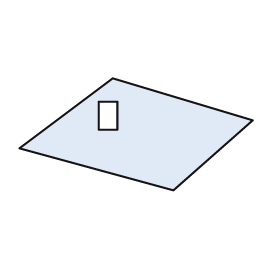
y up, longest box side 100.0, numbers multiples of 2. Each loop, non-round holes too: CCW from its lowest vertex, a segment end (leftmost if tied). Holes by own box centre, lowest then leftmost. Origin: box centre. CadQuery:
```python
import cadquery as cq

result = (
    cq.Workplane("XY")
    .moveTo(16.0, -24.0)
    .lineTo(50.0, 6.0)
    .lineTo(-10.0, 24.0)
    .lineTo(-50.0, -6.0)
    .close()
    .moveTo(-16.0, 2.0)
    .lineTo(-8.0, 2.0)
    .lineTo(-8.0, 14.0)
    .lineTo(-16.0, 14.0)
    .close()
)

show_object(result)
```